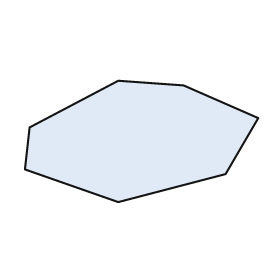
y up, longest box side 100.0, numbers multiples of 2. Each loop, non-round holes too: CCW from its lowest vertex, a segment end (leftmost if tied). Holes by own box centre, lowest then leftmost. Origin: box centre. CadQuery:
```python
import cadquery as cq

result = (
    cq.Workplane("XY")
    .moveTo(-10.0, -26.0)
    .lineTo(36.0, -14.0)
    .lineTo(50.0, 10.0)
    .lineTo(18.0, 24.0)
    .lineTo(-10.0, 26.0)
    .lineTo(-48.0, 6.0)
    .lineTo(-50.0, -12.0)
    .close()
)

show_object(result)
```